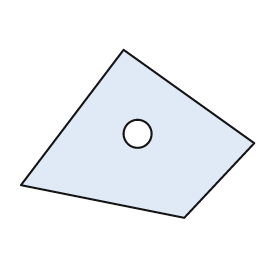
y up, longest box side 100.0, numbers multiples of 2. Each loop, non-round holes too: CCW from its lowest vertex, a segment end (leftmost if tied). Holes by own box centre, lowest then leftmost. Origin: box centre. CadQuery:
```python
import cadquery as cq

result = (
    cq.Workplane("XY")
    .moveTo(20.0, -36.0)
    .lineTo(50.0, -4.0)
    .lineTo(-6.0, 36.0)
    .lineTo(-50.0, -22.0)
    .close()
    .moveTo(0.0, 0.0)
    .circle(6.0)
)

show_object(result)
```